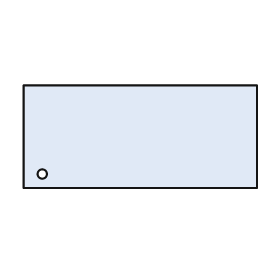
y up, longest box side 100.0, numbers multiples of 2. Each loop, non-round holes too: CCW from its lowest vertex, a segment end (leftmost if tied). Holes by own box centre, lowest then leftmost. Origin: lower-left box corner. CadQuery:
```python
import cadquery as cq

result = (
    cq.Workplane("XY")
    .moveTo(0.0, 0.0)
    .lineTo(100.0, 0.0)
    .lineTo(100.0, 44.0)
    .lineTo(0.0, 44.0)
    .close()
    .moveTo(8.0, 6.0)
    .circle(2.0)
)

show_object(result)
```